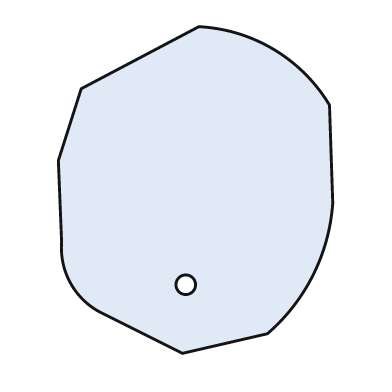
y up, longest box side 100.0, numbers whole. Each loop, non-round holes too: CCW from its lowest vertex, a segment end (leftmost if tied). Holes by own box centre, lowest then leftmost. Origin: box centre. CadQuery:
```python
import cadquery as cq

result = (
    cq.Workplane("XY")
    .moveTo(-4.0, -50.0)
    .lineTo(22.0, -44.0)
    .threePointArc((36.0, -26.0), (42.0, -4.0))
    .lineTo(41.0, 26.0)
    .threePointArc((24.0, 43.0), (1.0, 50.0))
    .lineTo(-35.0, 31.0)
    .lineTo(-42.0, 9.0)
    .lineTo(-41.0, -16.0)
    .threePointArc((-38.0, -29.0), (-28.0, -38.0))
    .close()
    .moveTo(-3.0, -29.0)
    .circle(3.0)
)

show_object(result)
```